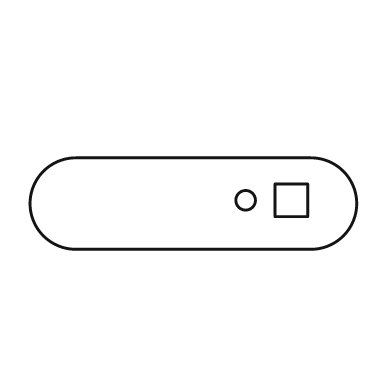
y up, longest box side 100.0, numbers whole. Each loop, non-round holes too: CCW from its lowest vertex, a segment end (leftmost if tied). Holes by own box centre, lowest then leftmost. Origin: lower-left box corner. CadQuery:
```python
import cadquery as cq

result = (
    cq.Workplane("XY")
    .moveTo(14.0, 0.0)
    .lineTo(86.0, 0.0)
    .threePointArc((100.0, 14.0), (86.0, 28.0))
    .lineTo(14.0, 28.0)
    .threePointArc((0.0, 14.0), (14.0, 0.0))
    .close()
    .moveTo(66.0, 15.0)
    .circle(3.0)
    .moveTo(75.0, 10.0)
    .lineTo(85.0, 10.0)
    .lineTo(85.0, 20.0)
    .lineTo(75.0, 20.0)
    .close()
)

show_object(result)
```